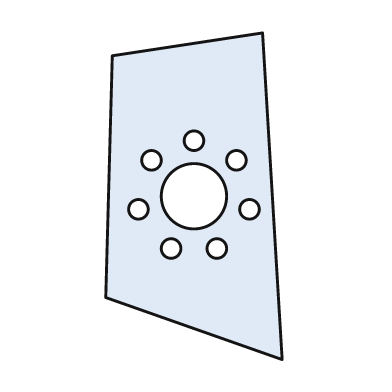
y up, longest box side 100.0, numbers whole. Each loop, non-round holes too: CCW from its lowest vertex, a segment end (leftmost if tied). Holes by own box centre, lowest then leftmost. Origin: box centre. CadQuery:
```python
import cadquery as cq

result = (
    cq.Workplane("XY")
    .moveTo(27.0, -50.0)
    .lineTo(21.0, 50.0)
    .lineTo(-25.0, 43.0)
    .lineTo(-27.0, -31.0)
    .close()
    .moveTo(-7.0, -16.0)
    .circle(3.0)
    .moveTo(7.0, -16.0)
    .circle(3.0)
    .moveTo(-17.0, -4.0)
    .circle(3.0)
    .moveTo(17.0, -4.0)
    .circle(3.0)
    .moveTo(0.0, 0.0)
    .circle(10.0)
    .moveTo(-13.0, 11.0)
    .circle(3.0)
    .moveTo(13.0, 11.0)
    .circle(3.0)
    .moveTo(0.0, 17.0)
    .circle(3.0)
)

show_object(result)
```